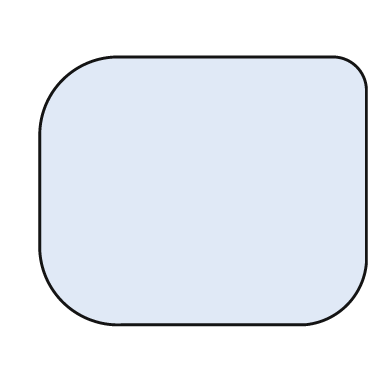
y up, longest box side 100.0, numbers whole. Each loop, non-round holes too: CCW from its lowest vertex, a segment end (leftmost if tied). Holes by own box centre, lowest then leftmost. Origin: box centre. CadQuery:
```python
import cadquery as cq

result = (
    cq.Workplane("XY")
    .moveTo(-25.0, -41.0)
    .lineTo(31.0, -41.0)
    .threePointArc((44.0, -35.0), (50.0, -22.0))
    .lineTo(50.0, 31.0)
    .threePointArc((47.0, 38.0), (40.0, 41.0))
    .lineTo(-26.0, 41.0)
    .threePointArc((-43.0, 34.0), (-50.0, 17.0))
    .lineTo(-50.0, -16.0)
    .threePointArc((-43.0, -34.0), (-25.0, -41.0))
    .close()
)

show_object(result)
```